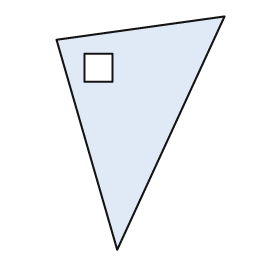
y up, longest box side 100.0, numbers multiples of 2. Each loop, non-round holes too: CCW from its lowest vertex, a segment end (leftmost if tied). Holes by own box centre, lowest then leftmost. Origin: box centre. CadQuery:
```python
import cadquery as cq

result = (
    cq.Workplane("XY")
    .moveTo(-10.0, -50.0)
    .lineTo(36.0, 50.0)
    .lineTo(-36.0, 40.0)
    .close()
    .moveTo(-24.0, 22.0)
    .lineTo(-12.0, 22.0)
    .lineTo(-12.0, 34.0)
    .lineTo(-24.0, 34.0)
    .close()
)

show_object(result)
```